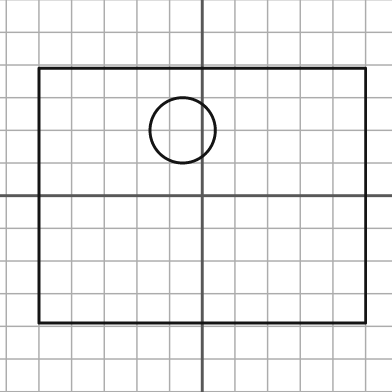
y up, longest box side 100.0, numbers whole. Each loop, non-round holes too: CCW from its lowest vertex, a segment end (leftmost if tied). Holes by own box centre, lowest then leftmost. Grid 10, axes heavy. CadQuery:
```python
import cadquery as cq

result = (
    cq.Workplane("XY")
    .moveTo(-50.0, -39.0)
    .lineTo(50.0, -39.0)
    .lineTo(50.0, 39.0)
    .lineTo(-50.0, 39.0)
    .close()
    .moveTo(-6.0, 20.0)
    .circle(10.0)
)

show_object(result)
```